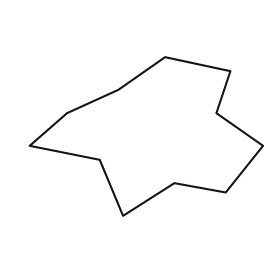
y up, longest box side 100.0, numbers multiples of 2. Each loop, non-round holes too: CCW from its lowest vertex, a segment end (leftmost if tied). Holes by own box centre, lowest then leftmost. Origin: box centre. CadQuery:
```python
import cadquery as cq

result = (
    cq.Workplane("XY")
    .moveTo(-10.0, -34.0)
    .lineTo(12.0, -20.0)
    .lineTo(34.0, -24.0)
    .lineTo(50.0, -4.0)
    .lineTo(30.0, 10.0)
    .lineTo(36.0, 28.0)
    .lineTo(8.0, 34.0)
    .lineTo(-12.0, 20.0)
    .lineTo(-34.0, 10.0)
    .lineTo(-50.0, -4.0)
    .lineTo(-20.0, -10.0)
    .close()
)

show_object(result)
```